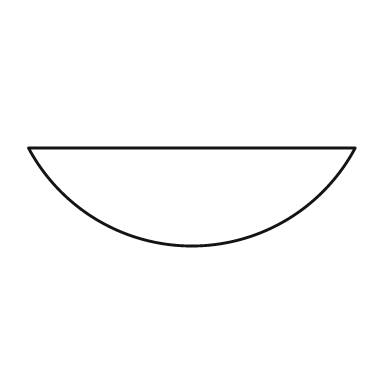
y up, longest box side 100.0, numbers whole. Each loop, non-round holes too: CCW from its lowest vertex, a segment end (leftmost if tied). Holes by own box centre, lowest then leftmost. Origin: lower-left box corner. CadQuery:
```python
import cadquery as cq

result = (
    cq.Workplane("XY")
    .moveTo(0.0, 30.0)
    .threePointArc((50.0, 0.0), (100.0, 30.0))
    .close()
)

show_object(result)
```